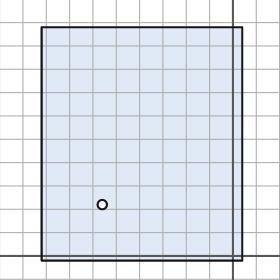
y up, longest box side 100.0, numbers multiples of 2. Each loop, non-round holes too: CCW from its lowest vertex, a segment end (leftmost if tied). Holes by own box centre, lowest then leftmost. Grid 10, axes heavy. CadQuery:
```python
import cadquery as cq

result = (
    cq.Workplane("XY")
    .moveTo(-82.0, -2.0)
    .lineTo(4.0, -2.0)
    .lineTo(4.0, 98.0)
    .lineTo(-82.0, 98.0)
    .close()
    .moveTo(-56.0, 22.0)
    .circle(2.0)
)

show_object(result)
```